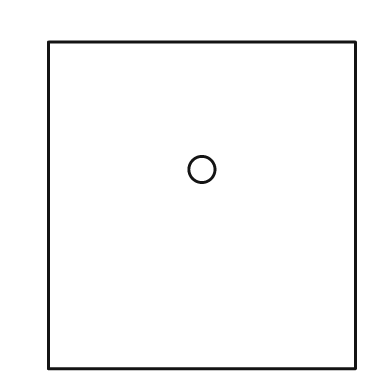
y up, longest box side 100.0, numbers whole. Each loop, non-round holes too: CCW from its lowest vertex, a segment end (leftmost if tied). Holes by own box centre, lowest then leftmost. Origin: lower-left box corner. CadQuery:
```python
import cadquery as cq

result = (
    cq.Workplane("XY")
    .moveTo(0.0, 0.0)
    .lineTo(94.0, 0.0)
    .lineTo(94.0, 100.0)
    .lineTo(0.0, 100.0)
    .close()
    .moveTo(47.0, 61.0)
    .circle(4.0)
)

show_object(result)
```